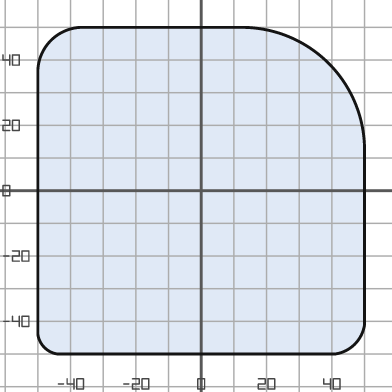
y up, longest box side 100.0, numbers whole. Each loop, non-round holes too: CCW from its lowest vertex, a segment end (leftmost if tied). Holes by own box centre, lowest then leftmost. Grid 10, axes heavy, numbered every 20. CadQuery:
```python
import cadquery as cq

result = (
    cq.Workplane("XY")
    .moveTo(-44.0, -50.0)
    .lineTo(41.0, -50.0)
    .threePointArc((47.0, -47.0), (50.0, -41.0))
    .lineTo(50.0, 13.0)
    .threePointArc((39.0, 39.0), (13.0, 50.0))
    .lineTo(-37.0, 50.0)
    .threePointArc((-46.0, 46.0), (-50.0, 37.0))
    .lineTo(-50.0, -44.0)
    .threePointArc((-48.0, -48.0), (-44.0, -50.0))
    .close()
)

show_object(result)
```